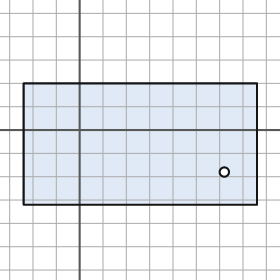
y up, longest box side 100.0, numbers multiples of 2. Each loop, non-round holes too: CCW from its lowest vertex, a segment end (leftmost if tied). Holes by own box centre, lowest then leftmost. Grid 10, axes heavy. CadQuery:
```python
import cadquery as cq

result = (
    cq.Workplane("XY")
    .moveTo(-24.0, -32.0)
    .lineTo(76.0, -32.0)
    .lineTo(76.0, 20.0)
    .lineTo(-24.0, 20.0)
    .close()
    .moveTo(62.0, -18.0)
    .circle(2.0)
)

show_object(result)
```